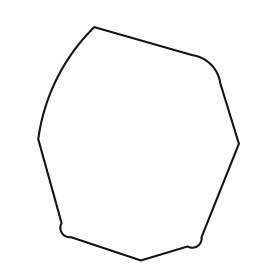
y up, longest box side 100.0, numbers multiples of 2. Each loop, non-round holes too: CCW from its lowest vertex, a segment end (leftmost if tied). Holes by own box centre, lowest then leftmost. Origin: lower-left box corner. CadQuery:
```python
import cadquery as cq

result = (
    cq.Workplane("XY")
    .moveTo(44.0, 0.0)
    .lineTo(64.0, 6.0)
    .threePointArc((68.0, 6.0), (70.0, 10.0))
    .lineTo(86.0, 50.0)
    .lineTo(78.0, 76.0)
    .threePointArc((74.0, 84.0), (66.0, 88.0))
    .lineTo(24.0, 100.0)
    .threePointArc((8.0, 78.0), (0.0, 52.0))
    .lineTo(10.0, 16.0)
    .threePointArc((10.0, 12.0), (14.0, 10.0))
    .close()
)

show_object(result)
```